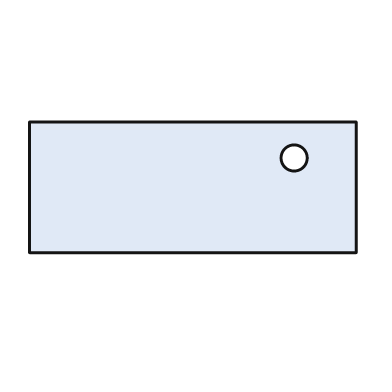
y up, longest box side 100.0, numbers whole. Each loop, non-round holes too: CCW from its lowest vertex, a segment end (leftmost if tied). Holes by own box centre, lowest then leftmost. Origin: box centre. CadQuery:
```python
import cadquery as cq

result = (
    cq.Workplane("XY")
    .moveTo(-50.0, -20.0)
    .lineTo(50.0, -20.0)
    .lineTo(50.0, 20.0)
    .lineTo(-50.0, 20.0)
    .close()
    .moveTo(31.0, 9.0)
    .circle(4.0)
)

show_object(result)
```